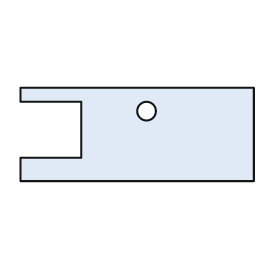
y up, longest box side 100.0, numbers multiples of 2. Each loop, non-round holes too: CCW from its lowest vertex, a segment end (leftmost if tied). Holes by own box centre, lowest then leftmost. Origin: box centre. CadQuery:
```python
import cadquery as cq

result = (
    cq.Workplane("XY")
    .moveTo(-50.0, -20.0)
    .lineTo(50.0, -20.0)
    .lineTo(50.0, 20.0)
    .lineTo(-50.0, 20.0)
    .lineTo(-50.0, 14.0)
    .lineTo(-24.0, 14.0)
    .lineTo(-24.0, -10.0)
    .lineTo(-50.0, -10.0)
    .close()
    .moveTo(4.0, 10.0)
    .circle(4.0)
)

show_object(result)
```